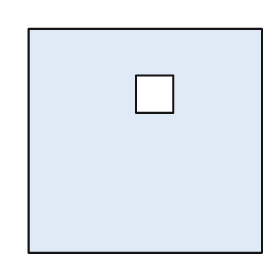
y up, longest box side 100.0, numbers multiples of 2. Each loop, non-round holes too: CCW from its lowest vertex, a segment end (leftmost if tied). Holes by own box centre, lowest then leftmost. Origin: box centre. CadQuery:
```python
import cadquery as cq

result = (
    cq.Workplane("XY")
    .moveTo(-50.0, -48.0)
    .lineTo(50.0, -48.0)
    .lineTo(50.0, 48.0)
    .lineTo(-50.0, 48.0)
    .close()
    .moveTo(-4.0, 12.0)
    .lineTo(12.0, 12.0)
    .lineTo(12.0, 28.0)
    .lineTo(-4.0, 28.0)
    .close()
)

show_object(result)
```